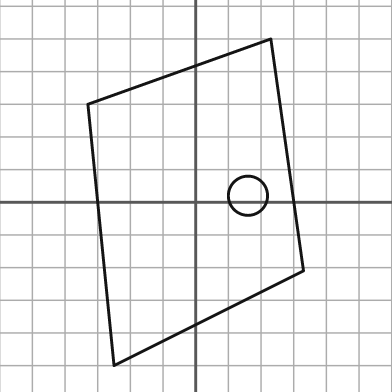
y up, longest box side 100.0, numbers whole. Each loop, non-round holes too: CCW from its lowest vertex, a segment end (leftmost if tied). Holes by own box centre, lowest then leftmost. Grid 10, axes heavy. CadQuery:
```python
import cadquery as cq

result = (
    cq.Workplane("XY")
    .moveTo(-25.0, -50.0)
    .lineTo(33.0, -21.0)
    .lineTo(23.0, 50.0)
    .lineTo(-33.0, 30.0)
    .close()
    .moveTo(16.0, 2.0)
    .circle(6.0)
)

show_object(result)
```